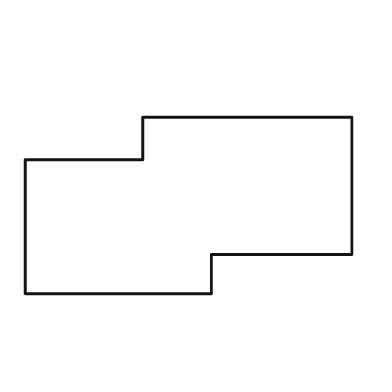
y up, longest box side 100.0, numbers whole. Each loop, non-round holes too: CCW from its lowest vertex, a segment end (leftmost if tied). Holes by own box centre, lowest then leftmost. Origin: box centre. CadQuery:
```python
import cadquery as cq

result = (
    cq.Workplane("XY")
    .moveTo(-50.0, -27.0)
    .lineTo(7.0, -27.0)
    .lineTo(7.0, -15.0)
    .lineTo(50.0, -15.0)
    .lineTo(50.0, 27.0)
    .lineTo(-14.0, 27.0)
    .lineTo(-14.0, 14.0)
    .lineTo(-50.0, 14.0)
    .close()
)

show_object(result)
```